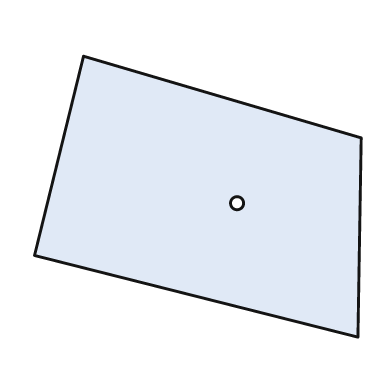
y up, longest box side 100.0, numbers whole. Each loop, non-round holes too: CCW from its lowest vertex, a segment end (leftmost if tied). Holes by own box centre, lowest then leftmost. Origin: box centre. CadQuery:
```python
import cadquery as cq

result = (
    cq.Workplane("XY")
    .moveTo(49.0, -43.0)
    .lineTo(50.0, 18.0)
    .lineTo(-35.0, 43.0)
    .lineTo(-50.0, -18.0)
    .close()
    .moveTo(12.0, -2.0)
    .circle(2.0)
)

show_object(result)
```